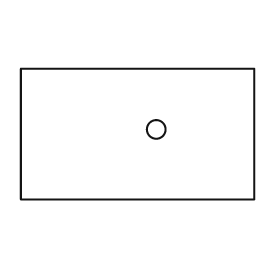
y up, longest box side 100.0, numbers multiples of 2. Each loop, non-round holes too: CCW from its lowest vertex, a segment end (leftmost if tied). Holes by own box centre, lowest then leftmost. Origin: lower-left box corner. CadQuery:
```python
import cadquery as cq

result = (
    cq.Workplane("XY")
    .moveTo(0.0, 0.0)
    .lineTo(100.0, 0.0)
    .lineTo(100.0, 56.0)
    .lineTo(0.0, 56.0)
    .close()
    .moveTo(58.0, 30.0)
    .circle(4.0)
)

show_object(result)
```